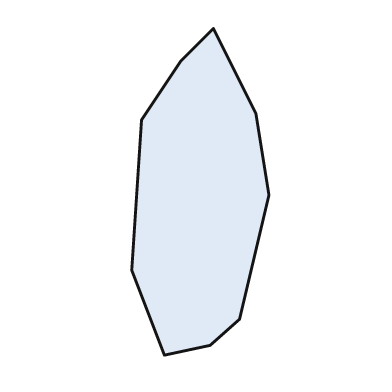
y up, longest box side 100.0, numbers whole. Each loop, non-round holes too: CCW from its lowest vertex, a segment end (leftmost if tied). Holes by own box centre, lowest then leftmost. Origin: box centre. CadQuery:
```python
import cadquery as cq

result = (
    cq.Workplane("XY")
    .moveTo(-11.0, -50.0)
    .lineTo(3.0, -47.0)
    .lineTo(12.0, -39.0)
    .lineTo(21.0, -1.0)
    .lineTo(17.0, 24.0)
    .lineTo(4.0, 50.0)
    .lineTo(-6.0, 40.0)
    .lineTo(-18.0, 22.0)
    .lineTo(-21.0, -24.0)
    .close()
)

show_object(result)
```